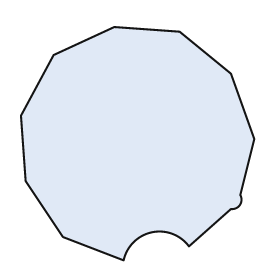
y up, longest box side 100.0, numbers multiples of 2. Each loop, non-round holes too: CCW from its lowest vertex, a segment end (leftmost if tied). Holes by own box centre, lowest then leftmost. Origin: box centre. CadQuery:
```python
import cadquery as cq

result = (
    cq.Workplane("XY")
    .moveTo(-6.0, -50.0)
    .threePointArc((6.0, -38.0), (22.0, -44.0))
    .lineTo(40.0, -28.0)
    .threePointArc((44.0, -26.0), (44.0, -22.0))
    .lineTo(50.0, 2.0)
    .lineTo(40.0, 30.0)
    .lineTo(18.0, 48.0)
    .lineTo(-10.0, 50.0)
    .lineTo(-36.0, 38.0)
    .lineTo(-50.0, 12.0)
    .lineTo(-48.0, -16.0)
    .lineTo(-32.0, -40.0)
    .close()
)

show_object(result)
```